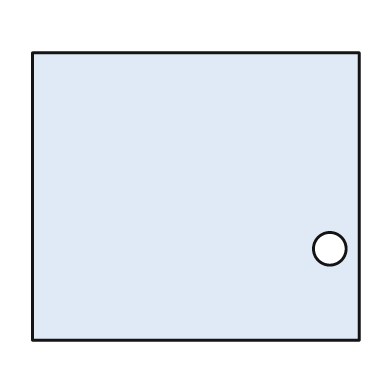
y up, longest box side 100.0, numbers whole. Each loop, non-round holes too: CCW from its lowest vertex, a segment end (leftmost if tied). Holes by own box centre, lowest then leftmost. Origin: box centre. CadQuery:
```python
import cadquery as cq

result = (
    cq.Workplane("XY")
    .moveTo(-50.0, -44.0)
    .lineTo(50.0, -44.0)
    .lineTo(50.0, 44.0)
    .lineTo(-50.0, 44.0)
    .close()
    .moveTo(41.0, -16.0)
    .circle(5.0)
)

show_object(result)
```